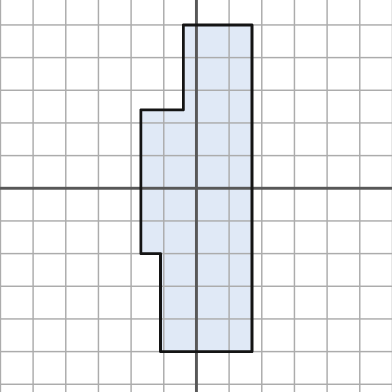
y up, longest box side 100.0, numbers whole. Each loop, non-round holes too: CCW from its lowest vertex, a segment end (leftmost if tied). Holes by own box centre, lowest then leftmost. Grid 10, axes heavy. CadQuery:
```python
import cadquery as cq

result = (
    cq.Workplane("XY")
    .moveTo(-11.0, -50.0)
    .lineTo(17.0, -50.0)
    .lineTo(17.0, 50.0)
    .lineTo(-4.0, 50.0)
    .lineTo(-4.0, 24.0)
    .lineTo(-17.0, 24.0)
    .lineTo(-17.0, -20.0)
    .lineTo(-11.0, -20.0)
    .close()
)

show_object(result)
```